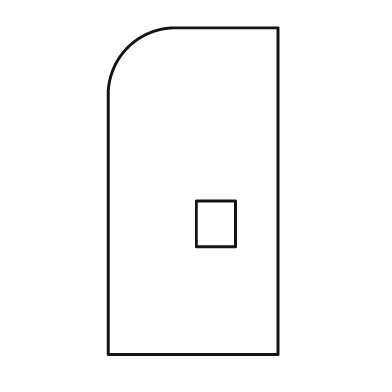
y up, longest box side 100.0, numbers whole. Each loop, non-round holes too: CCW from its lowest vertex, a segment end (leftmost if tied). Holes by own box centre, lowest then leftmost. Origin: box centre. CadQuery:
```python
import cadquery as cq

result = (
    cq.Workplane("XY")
    .moveTo(-26.0, -50.0)
    .lineTo(26.0, -50.0)
    .lineTo(26.0, 50.0)
    .lineTo(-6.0, 50.0)
    .threePointArc((-20.0, 44.0), (-26.0, 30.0))
    .close()
    .moveTo(1.0, -17.0)
    .lineTo(13.0, -17.0)
    .lineTo(13.0, -3.0)
    .lineTo(1.0, -3.0)
    .close()
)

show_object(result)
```